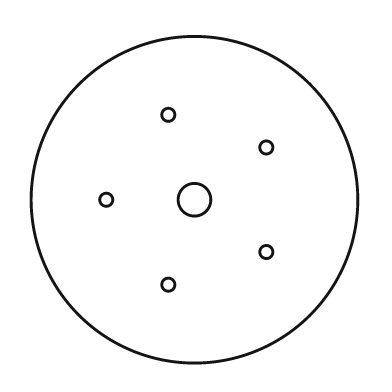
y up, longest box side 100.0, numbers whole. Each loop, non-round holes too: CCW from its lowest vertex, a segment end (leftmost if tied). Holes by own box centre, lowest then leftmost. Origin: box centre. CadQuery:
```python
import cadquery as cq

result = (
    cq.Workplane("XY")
    .moveTo(0.0, 0.0)
    .circle(50.0)
    .moveTo(-8.0, -26.0)
    .circle(2.0)
    .moveTo(22.0, -16.0)
    .circle(2.0)
    .moveTo(-27.0, 0.0)
    .circle(2.0)
    .moveTo(0.0, 0.0)
    .circle(5.0)
    .moveTo(22.0, 16.0)
    .circle(2.0)
    .moveTo(-8.0, 26.0)
    .circle(2.0)
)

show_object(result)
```